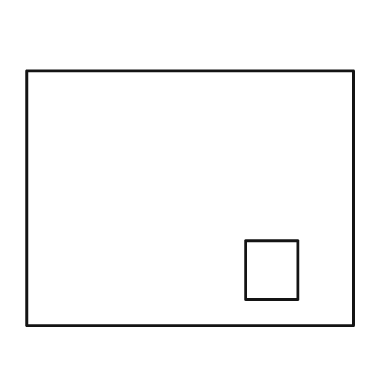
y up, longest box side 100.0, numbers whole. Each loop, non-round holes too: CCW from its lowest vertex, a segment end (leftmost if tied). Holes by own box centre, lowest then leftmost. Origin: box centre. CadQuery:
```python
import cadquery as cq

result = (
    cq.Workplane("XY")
    .moveTo(-50.0, -39.0)
    .lineTo(50.0, -39.0)
    .lineTo(50.0, 39.0)
    .lineTo(-50.0, 39.0)
    .close()
    .moveTo(17.0, -31.0)
    .lineTo(33.0, -31.0)
    .lineTo(33.0, -13.0)
    .lineTo(17.0, -13.0)
    .close()
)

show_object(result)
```